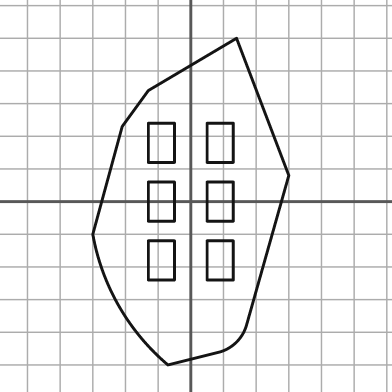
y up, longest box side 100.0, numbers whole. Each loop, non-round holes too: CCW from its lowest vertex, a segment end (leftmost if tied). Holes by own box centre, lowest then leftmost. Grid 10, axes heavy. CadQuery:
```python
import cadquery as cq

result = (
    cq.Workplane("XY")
    .moveTo(-7.0, -50.0)
    .lineTo(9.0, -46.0)
    .threePointArc((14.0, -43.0), (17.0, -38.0))
    .lineTo(30.0, 8.0)
    .lineTo(14.0, 50.0)
    .lineTo(-13.0, 34.0)
    .lineTo(-21.0, 23.0)
    .lineTo(-30.0, -10.0)
    .threePointArc((-22.0, -32.0), (-7.0, -50.0))
    .close()
    .moveTo(-13.0, -24.0)
    .lineTo(-5.0, -24.0)
    .lineTo(-5.0, -12.0)
    .lineTo(-13.0, -12.0)
    .close()
    .moveTo(5.0, -24.0)
    .lineTo(13.0, -24.0)
    .lineTo(13.0, -12.0)
    .lineTo(5.0, -12.0)
    .close()
    .moveTo(-13.0, -6.0)
    .lineTo(-5.0, -6.0)
    .lineTo(-5.0, 6.0)
    .lineTo(-13.0, 6.0)
    .close()
    .moveTo(5.0, -6.0)
    .lineTo(13.0, -6.0)
    .lineTo(13.0, 6.0)
    .lineTo(5.0, 6.0)
    .close()
    .moveTo(-13.0, 12.0)
    .lineTo(-5.0, 12.0)
    .lineTo(-5.0, 24.0)
    .lineTo(-13.0, 24.0)
    .close()
    .moveTo(5.0, 12.0)
    .lineTo(13.0, 12.0)
    .lineTo(13.0, 24.0)
    .lineTo(5.0, 24.0)
    .close()
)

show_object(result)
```